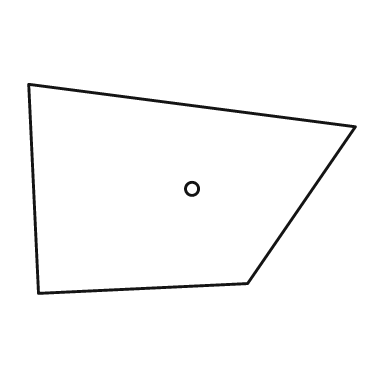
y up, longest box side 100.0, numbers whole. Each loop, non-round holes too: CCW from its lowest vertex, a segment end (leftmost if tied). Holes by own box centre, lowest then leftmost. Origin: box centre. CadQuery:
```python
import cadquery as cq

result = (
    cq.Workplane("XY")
    .moveTo(-47.0, -32.0)
    .lineTo(17.0, -29.0)
    .lineTo(50.0, 19.0)
    .lineTo(-50.0, 32.0)
    .close()
    .moveTo(0.0, 0.0)
    .circle(2.0)
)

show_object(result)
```